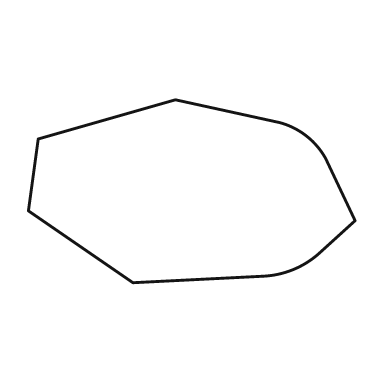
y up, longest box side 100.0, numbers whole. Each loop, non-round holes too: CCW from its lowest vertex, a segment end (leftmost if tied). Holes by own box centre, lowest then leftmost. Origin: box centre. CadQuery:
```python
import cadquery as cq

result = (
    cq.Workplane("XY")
    .moveTo(-18.0, -28.0)
    .lineTo(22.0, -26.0)
    .threePointArc((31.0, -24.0), (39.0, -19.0))
    .lineTo(50.0, -9.0)
    .lineTo(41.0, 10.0)
    .threePointArc((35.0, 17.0), (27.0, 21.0))
    .lineTo(-5.0, 28.0)
    .lineTo(-47.0, 16.0)
    .lineTo(-50.0, -6.0)
    .close()
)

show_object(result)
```